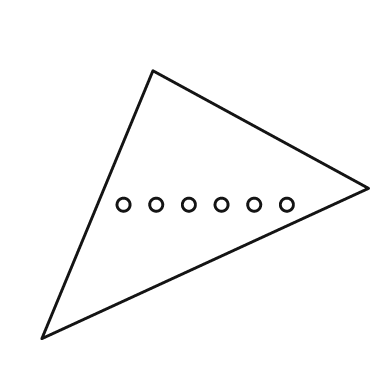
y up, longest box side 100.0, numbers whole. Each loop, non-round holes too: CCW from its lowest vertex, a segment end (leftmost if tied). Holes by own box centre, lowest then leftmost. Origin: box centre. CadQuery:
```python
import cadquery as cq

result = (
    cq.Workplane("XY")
    .moveTo(-50.0, -41.0)
    .lineTo(50.0, 5.0)
    .lineTo(-16.0, 41.0)
    .close()
    .moveTo(-25.0, 0.0)
    .circle(2.0)
    .moveTo(-15.0, 0.0)
    .circle(2.0)
    .moveTo(-5.0, 0.0)
    .circle(2.0)
    .moveTo(5.0, 0.0)
    .circle(2.0)
    .moveTo(15.0, 0.0)
    .circle(2.0)
    .moveTo(25.0, 0.0)
    .circle(2.0)
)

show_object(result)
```